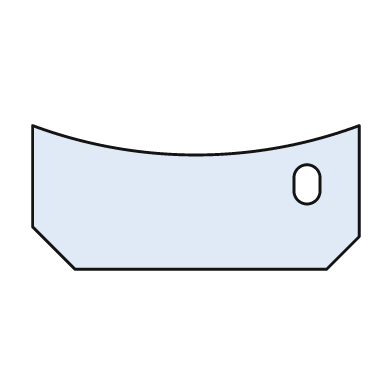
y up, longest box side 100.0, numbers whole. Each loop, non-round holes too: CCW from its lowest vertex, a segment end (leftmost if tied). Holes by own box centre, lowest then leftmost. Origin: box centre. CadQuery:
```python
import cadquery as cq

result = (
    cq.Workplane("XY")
    .moveTo(-37.0, -22.0)
    .lineTo(40.0, -22.0)
    .lineTo(50.0, -12.0)
    .lineTo(50.0, 22.0)
    .threePointArc((0.0, 13.0), (-50.0, 22.0))
    .lineTo(-50.0, -9.0)
    .close()
    .moveTo(30.0, 2.0)
    .threePointArc((34.0, -2.0), (38.0, 2.0))
    .lineTo(38.0, 6.0)
    .threePointArc((34.0, 10.0), (30.0, 6.0))
    .close()
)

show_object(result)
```